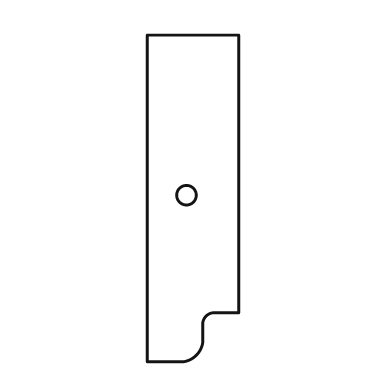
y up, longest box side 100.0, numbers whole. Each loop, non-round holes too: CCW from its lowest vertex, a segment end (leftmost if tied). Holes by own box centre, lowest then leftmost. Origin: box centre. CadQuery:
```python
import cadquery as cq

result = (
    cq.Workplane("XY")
    .moveTo(-14.0, -50.0)
    .lineTo(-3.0, -50.0)
    .threePointArc((1.0, -48.0), (3.0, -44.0))
    .lineTo(3.0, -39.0)
    .threePointArc((4.0, -36.0), (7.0, -35.0))
    .lineTo(14.0, -35.0)
    .lineTo(14.0, 50.0)
    .lineTo(-14.0, 50.0)
    .close()
    .moveTo(-2.0, 1.0)
    .circle(3.0)
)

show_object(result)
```